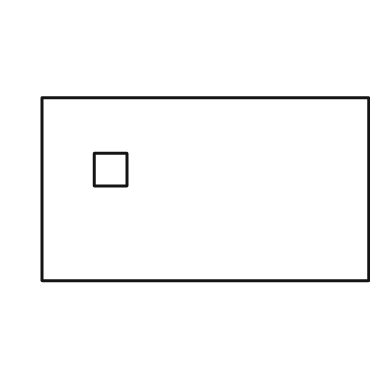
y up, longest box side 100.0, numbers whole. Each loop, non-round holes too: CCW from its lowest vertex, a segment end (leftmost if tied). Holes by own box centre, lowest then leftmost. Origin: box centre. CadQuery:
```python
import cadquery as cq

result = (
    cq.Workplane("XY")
    .moveTo(-50.0, -28.0)
    .lineTo(50.0, -28.0)
    .lineTo(50.0, 28.0)
    .lineTo(-50.0, 28.0)
    .close()
    .moveTo(-34.0, 1.0)
    .lineTo(-24.0, 1.0)
    .lineTo(-24.0, 11.0)
    .lineTo(-34.0, 11.0)
    .close()
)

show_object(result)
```